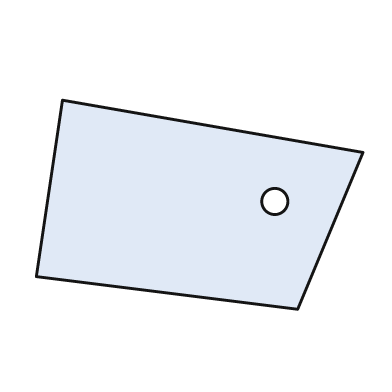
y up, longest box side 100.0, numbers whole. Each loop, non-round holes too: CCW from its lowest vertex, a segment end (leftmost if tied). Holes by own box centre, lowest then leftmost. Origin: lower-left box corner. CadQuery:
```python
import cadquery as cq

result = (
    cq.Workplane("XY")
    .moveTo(80.0, 0.0)
    .lineTo(100.0, 48.0)
    .lineTo(8.0, 64.0)
    .lineTo(0.0, 10.0)
    .close()
    .moveTo(73.0, 33.0)
    .circle(4.0)
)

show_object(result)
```